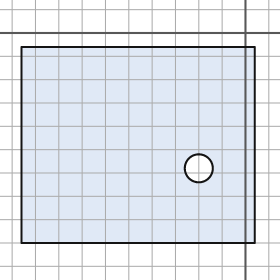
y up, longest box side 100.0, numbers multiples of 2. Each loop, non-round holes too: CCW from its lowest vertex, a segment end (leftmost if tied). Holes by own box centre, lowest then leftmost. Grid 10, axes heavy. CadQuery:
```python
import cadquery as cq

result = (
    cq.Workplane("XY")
    .moveTo(-96.0, -90.0)
    .lineTo(4.0, -90.0)
    .lineTo(4.0, -6.0)
    .lineTo(-96.0, -6.0)
    .close()
    .moveTo(-20.0, -58.0)
    .circle(6.0)
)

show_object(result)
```